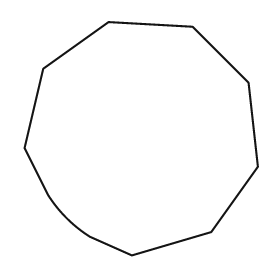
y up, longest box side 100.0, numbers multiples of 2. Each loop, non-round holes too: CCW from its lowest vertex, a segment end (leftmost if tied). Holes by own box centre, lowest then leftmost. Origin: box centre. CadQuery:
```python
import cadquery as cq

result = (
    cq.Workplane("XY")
    .moveTo(-4.0, -50.0)
    .lineTo(30.0, -40.0)
    .lineTo(50.0, -12.0)
    .lineTo(46.0, 24.0)
    .lineTo(22.0, 48.0)
    .lineTo(-14.0, 50.0)
    .lineTo(-42.0, 30.0)
    .lineTo(-50.0, -4.0)
    .lineTo(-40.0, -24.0)
    .threePointArc((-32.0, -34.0), (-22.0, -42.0))
    .close()
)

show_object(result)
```